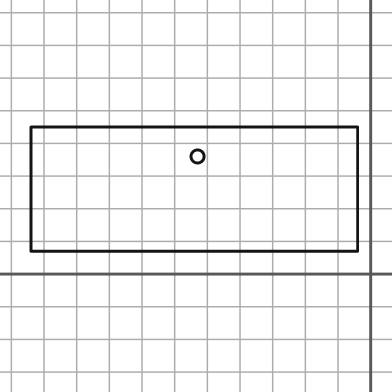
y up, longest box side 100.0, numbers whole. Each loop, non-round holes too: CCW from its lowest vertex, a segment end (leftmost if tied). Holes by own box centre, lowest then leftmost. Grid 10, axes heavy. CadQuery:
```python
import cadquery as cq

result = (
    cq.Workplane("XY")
    .moveTo(-104.0, 7.0)
    .lineTo(-4.0, 7.0)
    .lineTo(-4.0, 45.0)
    .lineTo(-104.0, 45.0)
    .close()
    .moveTo(-53.0, 36.0)
    .circle(2.0)
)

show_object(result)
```